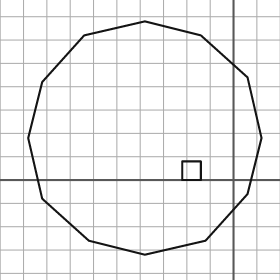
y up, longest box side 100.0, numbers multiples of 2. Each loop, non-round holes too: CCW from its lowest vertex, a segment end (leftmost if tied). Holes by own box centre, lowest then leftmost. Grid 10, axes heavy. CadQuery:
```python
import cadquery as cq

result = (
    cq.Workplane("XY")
    .moveTo(-38.0, -32.0)
    .lineTo(-12.0, -26.0)
    .lineTo(6.0, -6.0)
    .lineTo(12.0, 18.0)
    .lineTo(6.0, 44.0)
    .lineTo(-14.0, 62.0)
    .lineTo(-38.0, 68.0)
    .lineTo(-64.0, 62.0)
    .lineTo(-82.0, 42.0)
    .lineTo(-88.0, 18.0)
    .lineTo(-82.0, -8.0)
    .lineTo(-62.0, -26.0)
    .close()
    .moveTo(-22.0, 0.0)
    .lineTo(-14.0, 0.0)
    .lineTo(-14.0, 8.0)
    .lineTo(-22.0, 8.0)
    .close()
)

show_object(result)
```